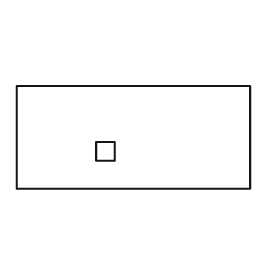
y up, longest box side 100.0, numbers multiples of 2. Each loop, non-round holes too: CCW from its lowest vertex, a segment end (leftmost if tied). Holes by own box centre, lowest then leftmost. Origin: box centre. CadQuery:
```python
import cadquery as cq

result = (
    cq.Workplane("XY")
    .moveTo(-50.0, -22.0)
    .lineTo(50.0, -22.0)
    .lineTo(50.0, 22.0)
    .lineTo(-50.0, 22.0)
    .close()
    .moveTo(-16.0, -10.0)
    .lineTo(-8.0, -10.0)
    .lineTo(-8.0, -2.0)
    .lineTo(-16.0, -2.0)
    .close()
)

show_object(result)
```